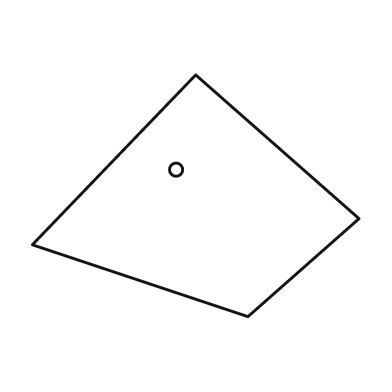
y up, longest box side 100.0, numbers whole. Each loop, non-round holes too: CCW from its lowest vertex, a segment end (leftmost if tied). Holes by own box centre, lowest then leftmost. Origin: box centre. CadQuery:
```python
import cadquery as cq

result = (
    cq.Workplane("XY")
    .moveTo(16.0, -37.0)
    .lineTo(50.0, -7.0)
    .lineTo(0.0, 37.0)
    .lineTo(-50.0, -15.0)
    .close()
    .moveTo(-6.0, 8.0)
    .circle(2.0)
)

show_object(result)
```